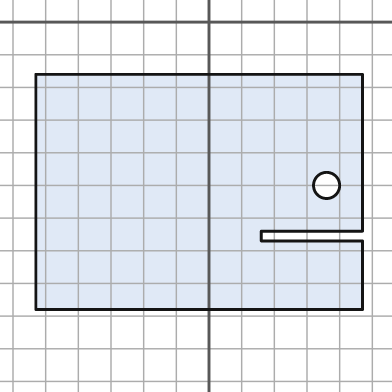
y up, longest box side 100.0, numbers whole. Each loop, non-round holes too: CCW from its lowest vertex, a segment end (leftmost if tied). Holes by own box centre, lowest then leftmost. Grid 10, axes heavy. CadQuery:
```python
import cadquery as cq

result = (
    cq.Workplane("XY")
    .moveTo(-53.0, -88.0)
    .lineTo(47.0, -88.0)
    .lineTo(47.0, -67.0)
    .lineTo(16.0, -67.0)
    .lineTo(16.0, -64.0)
    .lineTo(47.0, -64.0)
    .lineTo(47.0, -16.0)
    .lineTo(-53.0, -16.0)
    .close()
    .moveTo(36.0, -50.0)
    .circle(4.0)
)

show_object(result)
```